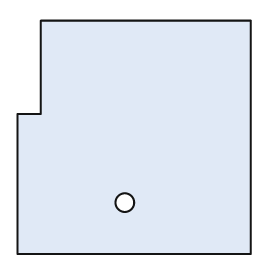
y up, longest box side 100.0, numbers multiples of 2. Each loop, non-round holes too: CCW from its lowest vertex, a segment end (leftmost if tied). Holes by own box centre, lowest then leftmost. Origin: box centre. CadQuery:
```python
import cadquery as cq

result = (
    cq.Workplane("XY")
    .moveTo(-50.0, -50.0)
    .lineTo(50.0, -50.0)
    .lineTo(50.0, 50.0)
    .lineTo(-40.0, 50.0)
    .lineTo(-40.0, 10.0)
    .lineTo(-50.0, 10.0)
    .close()
    .moveTo(-4.0, -28.0)
    .circle(4.0)
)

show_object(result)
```